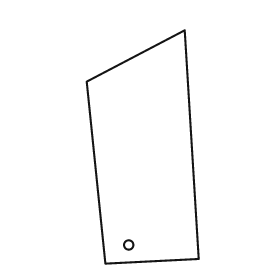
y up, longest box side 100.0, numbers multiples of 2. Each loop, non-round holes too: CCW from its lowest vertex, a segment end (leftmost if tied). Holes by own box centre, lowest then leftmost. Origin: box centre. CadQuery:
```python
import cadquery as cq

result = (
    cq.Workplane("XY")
    .moveTo(-16.0, -50.0)
    .lineTo(24.0, -48.0)
    .lineTo(18.0, 50.0)
    .lineTo(-24.0, 28.0)
    .close()
    .moveTo(-6.0, -42.0)
    .circle(2.0)
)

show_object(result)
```